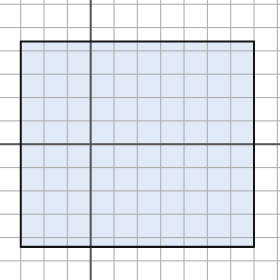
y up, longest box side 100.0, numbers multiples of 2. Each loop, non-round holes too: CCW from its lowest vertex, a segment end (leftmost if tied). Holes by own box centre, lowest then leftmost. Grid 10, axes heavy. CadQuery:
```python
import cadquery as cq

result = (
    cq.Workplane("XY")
    .moveTo(-30.0, -44.0)
    .lineTo(70.0, -44.0)
    .lineTo(70.0, 44.0)
    .lineTo(-30.0, 44.0)
    .close()
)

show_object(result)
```